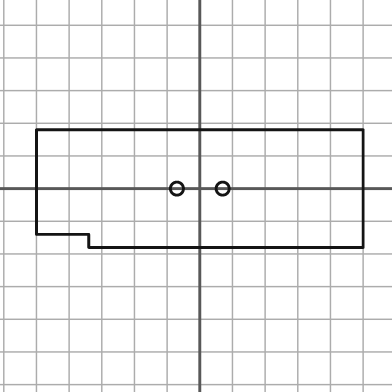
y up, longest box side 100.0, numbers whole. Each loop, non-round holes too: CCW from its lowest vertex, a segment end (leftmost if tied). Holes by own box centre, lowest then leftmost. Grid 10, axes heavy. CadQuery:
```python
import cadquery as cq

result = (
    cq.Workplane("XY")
    .moveTo(-34.0, -18.0)
    .lineTo(50.0, -18.0)
    .lineTo(50.0, 18.0)
    .lineTo(-50.0, 18.0)
    .lineTo(-50.0, -14.0)
    .lineTo(-34.0, -14.0)
    .close()
    .moveTo(-7.0, 0.0)
    .circle(2.0)
    .moveTo(7.0, 0.0)
    .circle(2.0)
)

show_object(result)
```